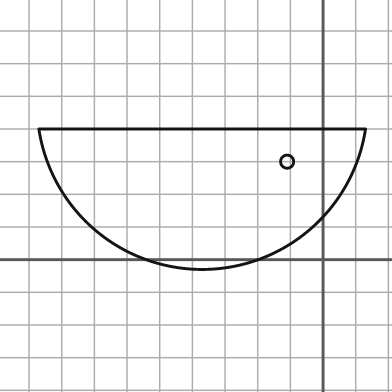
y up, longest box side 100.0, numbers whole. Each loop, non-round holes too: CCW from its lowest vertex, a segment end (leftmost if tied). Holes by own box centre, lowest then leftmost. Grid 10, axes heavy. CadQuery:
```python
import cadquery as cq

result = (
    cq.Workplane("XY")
    .moveTo(-87.0, 40.0)
    .threePointArc((-37.0, -3.0), (13.0, 40.0))
    .close()
    .moveTo(-11.0, 30.0)
    .circle(2.0)
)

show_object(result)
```